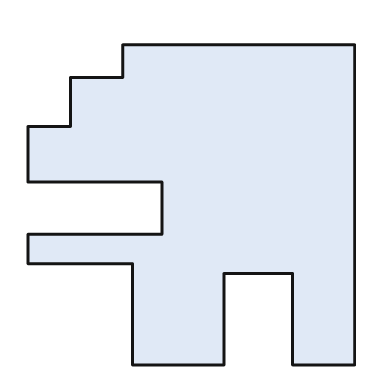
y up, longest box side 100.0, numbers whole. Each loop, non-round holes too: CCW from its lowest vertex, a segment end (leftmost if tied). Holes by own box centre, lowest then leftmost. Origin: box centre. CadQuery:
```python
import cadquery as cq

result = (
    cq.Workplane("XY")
    .moveTo(-18.0, -49.0)
    .lineTo(10.0, -49.0)
    .lineTo(10.0, -21.0)
    .lineTo(31.0, -21.0)
    .lineTo(31.0, -49.0)
    .lineTo(50.0, -49.0)
    .lineTo(50.0, 49.0)
    .lineTo(-21.0, 49.0)
    .lineTo(-21.0, 39.0)
    .lineTo(-37.0, 39.0)
    .lineTo(-37.0, 24.0)
    .lineTo(-50.0, 24.0)
    .lineTo(-50.0, 7.0)
    .lineTo(-9.0, 7.0)
    .lineTo(-9.0, -9.0)
    .lineTo(-50.0, -9.0)
    .lineTo(-50.0, -18.0)
    .lineTo(-18.0, -18.0)
    .close()
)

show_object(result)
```